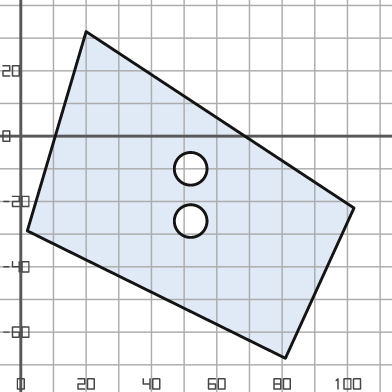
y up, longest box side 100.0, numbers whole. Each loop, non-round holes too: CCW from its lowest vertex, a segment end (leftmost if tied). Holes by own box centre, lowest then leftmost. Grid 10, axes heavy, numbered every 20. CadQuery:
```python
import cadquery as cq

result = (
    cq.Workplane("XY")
    .moveTo(81.0, -68.0)
    .lineTo(102.0, -22.0)
    .lineTo(20.0, 32.0)
    .lineTo(2.0, -29.0)
    .close()
    .moveTo(52.0, -26.0)
    .circle(5.0)
    .moveTo(52.0, -10.0)
    .circle(5.0)
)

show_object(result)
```